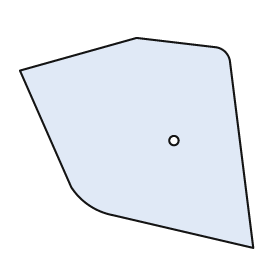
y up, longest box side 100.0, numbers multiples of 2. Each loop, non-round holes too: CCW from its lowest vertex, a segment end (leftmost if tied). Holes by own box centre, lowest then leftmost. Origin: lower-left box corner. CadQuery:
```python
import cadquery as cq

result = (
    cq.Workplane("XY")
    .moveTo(100.0, 0.0)
    .lineTo(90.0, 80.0)
    .threePointArc((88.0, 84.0), (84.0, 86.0))
    .lineTo(50.0, 90.0)
    .lineTo(0.0, 76.0)
    .lineTo(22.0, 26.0)
    .threePointArc((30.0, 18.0), (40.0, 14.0))
    .close()
    .moveTo(66.0, 46.0)
    .circle(2.0)
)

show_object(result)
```